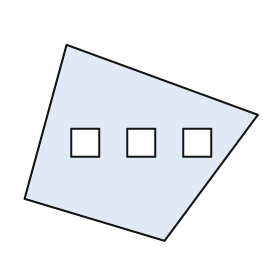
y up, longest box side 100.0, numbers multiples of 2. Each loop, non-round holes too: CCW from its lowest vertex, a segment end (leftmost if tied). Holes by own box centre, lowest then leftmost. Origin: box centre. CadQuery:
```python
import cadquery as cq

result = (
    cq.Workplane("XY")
    .moveTo(10.0, -42.0)
    .lineTo(50.0, 12.0)
    .lineTo(-32.0, 42.0)
    .lineTo(-50.0, -24.0)
    .close()
    .moveTo(-30.0, -6.0)
    .lineTo(-18.0, -6.0)
    .lineTo(-18.0, 6.0)
    .lineTo(-30.0, 6.0)
    .close()
    .moveTo(-6.0, -6.0)
    .lineTo(6.0, -6.0)
    .lineTo(6.0, 6.0)
    .lineTo(-6.0, 6.0)
    .close()
    .moveTo(18.0, -6.0)
    .lineTo(30.0, -6.0)
    .lineTo(30.0, 6.0)
    .lineTo(18.0, 6.0)
    .close()
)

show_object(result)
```